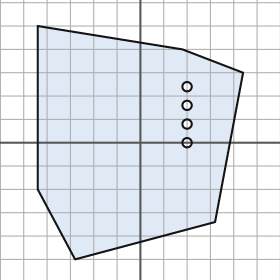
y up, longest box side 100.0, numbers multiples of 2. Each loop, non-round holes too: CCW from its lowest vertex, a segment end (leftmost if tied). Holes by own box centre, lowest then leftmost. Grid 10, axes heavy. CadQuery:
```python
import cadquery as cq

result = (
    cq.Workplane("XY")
    .moveTo(-28.0, -50.0)
    .lineTo(32.0, -34.0)
    .lineTo(44.0, 30.0)
    .lineTo(18.0, 40.0)
    .lineTo(-44.0, 50.0)
    .lineTo(-44.0, -20.0)
    .close()
    .moveTo(20.0, 0.0)
    .circle(2.0)
    .moveTo(20.0, 8.0)
    .circle(2.0)
    .moveTo(20.0, 16.0)
    .circle(2.0)
    .moveTo(20.0, 24.0)
    .circle(2.0)
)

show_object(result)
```